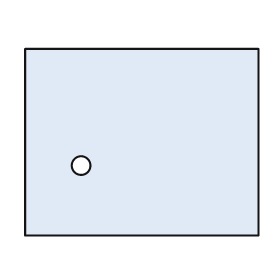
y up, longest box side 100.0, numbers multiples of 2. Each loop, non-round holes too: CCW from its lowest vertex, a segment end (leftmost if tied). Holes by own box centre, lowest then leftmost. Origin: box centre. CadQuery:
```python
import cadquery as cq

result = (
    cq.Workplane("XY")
    .moveTo(-50.0, -40.0)
    .lineTo(50.0, -40.0)
    .lineTo(50.0, 40.0)
    .lineTo(-50.0, 40.0)
    .close()
    .moveTo(-26.0, -10.0)
    .circle(4.0)
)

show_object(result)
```